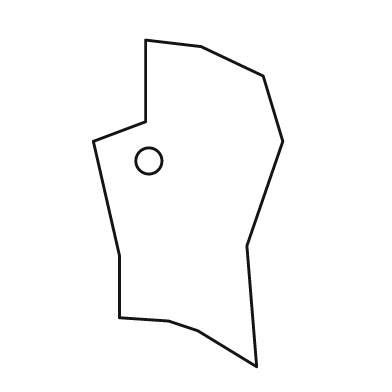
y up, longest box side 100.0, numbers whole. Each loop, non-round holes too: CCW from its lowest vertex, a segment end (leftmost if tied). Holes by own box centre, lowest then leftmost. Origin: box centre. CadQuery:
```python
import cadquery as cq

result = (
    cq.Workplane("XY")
    .moveTo(21.0, -50.0)
    .lineTo(18.0, -13.0)
    .lineTo(29.0, 19.0)
    .lineTo(23.0, 39.0)
    .lineTo(4.0, 48.0)
    .lineTo(-13.0, 50.0)
    .lineTo(-13.0, 25.0)
    .lineTo(-29.0, 19.0)
    .lineTo(-21.0, -16.0)
    .lineTo(-21.0, -35.0)
    .lineTo(-6.0, -36.0)
    .lineTo(3.0, -39.0)
    .close()
    .moveTo(-12.0, 13.0)
    .circle(4.0)
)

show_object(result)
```